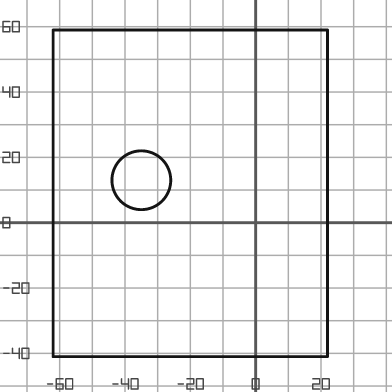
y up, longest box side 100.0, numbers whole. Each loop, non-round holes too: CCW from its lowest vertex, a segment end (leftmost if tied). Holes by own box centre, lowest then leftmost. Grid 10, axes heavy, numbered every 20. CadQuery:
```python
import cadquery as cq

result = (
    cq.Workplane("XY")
    .moveTo(-62.0, -41.0)
    .lineTo(22.0, -41.0)
    .lineTo(22.0, 59.0)
    .lineTo(-62.0, 59.0)
    .close()
    .moveTo(-35.0, 13.0)
    .circle(9.0)
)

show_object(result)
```